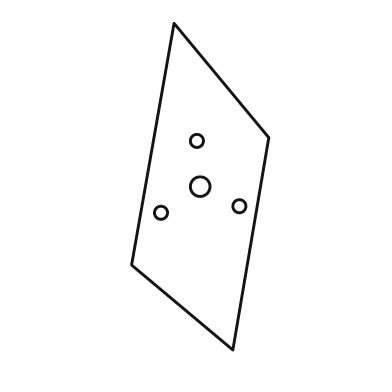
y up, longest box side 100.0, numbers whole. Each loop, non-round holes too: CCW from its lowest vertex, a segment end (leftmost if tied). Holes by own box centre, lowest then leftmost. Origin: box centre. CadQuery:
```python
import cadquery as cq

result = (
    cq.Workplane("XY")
    .moveTo(10.0, -50.0)
    .lineTo(21.0, 15.0)
    .lineTo(-8.0, 50.0)
    .lineTo(-21.0, -24.0)
    .close()
    .moveTo(-12.0, -8.0)
    .circle(2.0)
    .moveTo(12.0, -6.0)
    .circle(2.0)
    .moveTo(0.0, 0.0)
    .circle(3.0)
    .moveTo(-1.0, 14.0)
    .circle(2.0)
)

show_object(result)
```